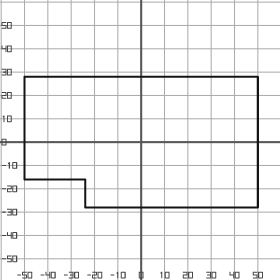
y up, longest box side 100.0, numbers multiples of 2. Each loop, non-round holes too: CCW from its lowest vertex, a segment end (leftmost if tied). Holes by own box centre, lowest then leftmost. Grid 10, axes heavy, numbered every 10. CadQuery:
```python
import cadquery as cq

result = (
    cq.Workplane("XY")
    .moveTo(-24.0, -28.0)
    .lineTo(50.0, -28.0)
    .lineTo(50.0, 28.0)
    .lineTo(-50.0, 28.0)
    .lineTo(-50.0, -16.0)
    .lineTo(-24.0, -16.0)
    .close()
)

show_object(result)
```